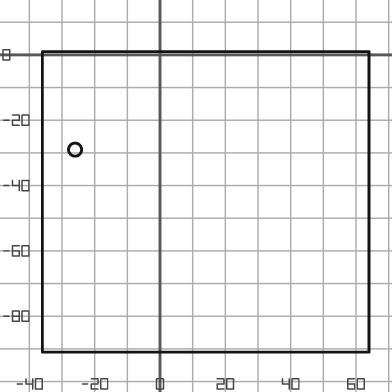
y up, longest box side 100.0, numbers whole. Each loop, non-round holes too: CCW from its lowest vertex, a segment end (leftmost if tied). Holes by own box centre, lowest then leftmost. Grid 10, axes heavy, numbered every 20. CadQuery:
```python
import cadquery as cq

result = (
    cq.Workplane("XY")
    .moveTo(-36.0, -91.0)
    .lineTo(64.0, -91.0)
    .lineTo(64.0, 1.0)
    .lineTo(-36.0, 1.0)
    .close()
    .moveTo(-26.0, -29.0)
    .circle(2.0)
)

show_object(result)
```